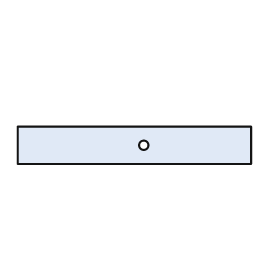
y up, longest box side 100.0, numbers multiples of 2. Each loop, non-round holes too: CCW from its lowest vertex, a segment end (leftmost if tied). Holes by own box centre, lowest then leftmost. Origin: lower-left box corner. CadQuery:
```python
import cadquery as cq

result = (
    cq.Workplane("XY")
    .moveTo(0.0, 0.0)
    .lineTo(100.0, 0.0)
    .lineTo(100.0, 16.0)
    .lineTo(0.0, 16.0)
    .close()
    .moveTo(54.0, 8.0)
    .circle(2.0)
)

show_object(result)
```